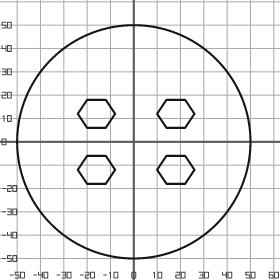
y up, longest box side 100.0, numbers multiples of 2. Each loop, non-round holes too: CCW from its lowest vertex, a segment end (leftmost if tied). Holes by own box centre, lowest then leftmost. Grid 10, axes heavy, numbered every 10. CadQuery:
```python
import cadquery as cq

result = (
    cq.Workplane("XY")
    .moveTo(0.0, 0.0)
    .circle(50.0)
    .moveTo(-20.0, -18.0)
    .lineTo(-12.0, -18.0)
    .lineTo(-8.0, -12.0)
    .lineTo(-12.0, -6.0)
    .lineTo(-20.0, -6.0)
    .lineTo(-24.0, -12.0)
    .close()
    .moveTo(14.0, -18.0)
    .lineTo(22.0, -18.0)
    .lineTo(26.0, -12.0)
    .lineTo(22.0, -6.0)
    .lineTo(14.0, -6.0)
    .lineTo(10.0, -12.0)
    .close()
    .moveTo(-20.0, 6.0)
    .lineTo(-12.0, 6.0)
    .lineTo(-8.0, 12.0)
    .lineTo(-12.0, 18.0)
    .lineTo(-20.0, 18.0)
    .lineTo(-24.0, 12.0)
    .close()
    .moveTo(14.0, 6.0)
    .lineTo(22.0, 6.0)
    .lineTo(26.0, 12.0)
    .lineTo(22.0, 18.0)
    .lineTo(14.0, 18.0)
    .lineTo(10.0, 12.0)
    .close()
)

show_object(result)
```